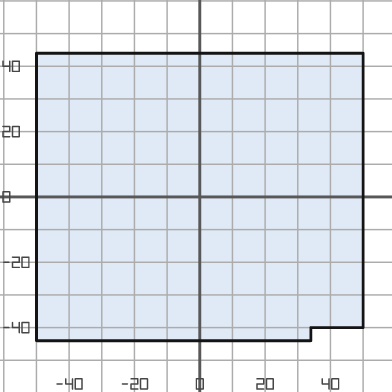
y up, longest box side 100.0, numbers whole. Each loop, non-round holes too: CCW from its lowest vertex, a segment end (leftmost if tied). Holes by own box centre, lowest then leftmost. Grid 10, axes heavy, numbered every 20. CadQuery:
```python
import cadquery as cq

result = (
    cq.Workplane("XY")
    .moveTo(-50.0, -44.0)
    .lineTo(34.0, -44.0)
    .lineTo(34.0, -40.0)
    .lineTo(50.0, -40.0)
    .lineTo(50.0, 44.0)
    .lineTo(-50.0, 44.0)
    .close()
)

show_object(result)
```